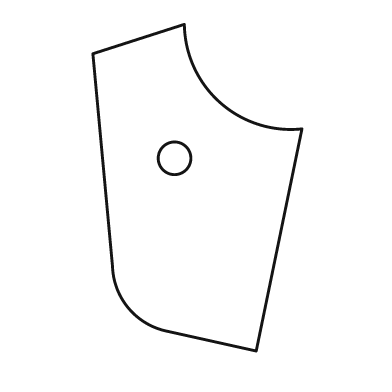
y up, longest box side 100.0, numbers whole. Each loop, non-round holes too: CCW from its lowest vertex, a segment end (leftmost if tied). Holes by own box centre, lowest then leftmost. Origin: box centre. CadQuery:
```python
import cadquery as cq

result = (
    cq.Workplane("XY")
    .moveTo(18.0, -50.0)
    .lineTo(32.0, 18.0)
    .threePointArc((7.0, 26.0), (-4.0, 50.0))
    .lineTo(-32.0, 41.0)
    .lineTo(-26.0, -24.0)
    .threePointArc((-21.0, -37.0), (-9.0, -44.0))
    .close()
    .moveTo(-7.0, 9.0)
    .circle(5.0)
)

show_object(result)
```